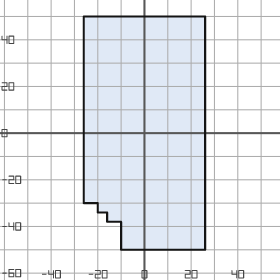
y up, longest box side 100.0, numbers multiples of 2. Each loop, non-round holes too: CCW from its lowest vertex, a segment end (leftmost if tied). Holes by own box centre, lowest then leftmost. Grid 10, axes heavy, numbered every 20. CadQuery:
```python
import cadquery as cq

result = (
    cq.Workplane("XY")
    .moveTo(-10.0, -50.0)
    .lineTo(26.0, -50.0)
    .lineTo(26.0, 50.0)
    .lineTo(-26.0, 50.0)
    .lineTo(-26.0, -30.0)
    .lineTo(-20.0, -30.0)
    .lineTo(-20.0, -34.0)
    .lineTo(-16.0, -34.0)
    .lineTo(-16.0, -38.0)
    .lineTo(-10.0, -38.0)
    .close()
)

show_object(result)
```